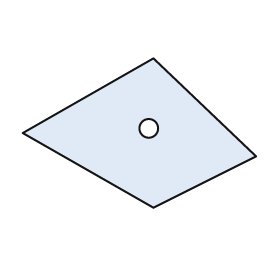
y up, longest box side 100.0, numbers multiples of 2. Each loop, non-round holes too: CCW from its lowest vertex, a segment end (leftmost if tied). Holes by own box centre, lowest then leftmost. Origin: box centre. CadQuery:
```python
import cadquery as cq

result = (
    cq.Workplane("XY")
    .moveTo(6.0, -32.0)
    .lineTo(50.0, -10.0)
    .lineTo(6.0, 32.0)
    .lineTo(-50.0, 0.0)
    .close()
    .moveTo(4.0, 2.0)
    .circle(4.0)
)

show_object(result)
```